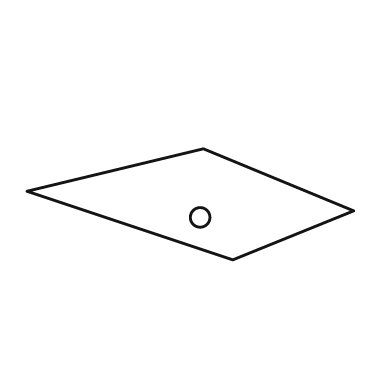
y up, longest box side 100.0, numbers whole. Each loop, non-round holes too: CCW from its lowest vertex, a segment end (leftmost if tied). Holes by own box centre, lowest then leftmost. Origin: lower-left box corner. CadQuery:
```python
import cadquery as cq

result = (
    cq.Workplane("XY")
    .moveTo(63.0, 0.0)
    .lineTo(100.0, 15.0)
    .lineTo(54.0, 34.0)
    .lineTo(0.0, 21.0)
    .close()
    .moveTo(53.0, 13.0)
    .circle(3.0)
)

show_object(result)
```